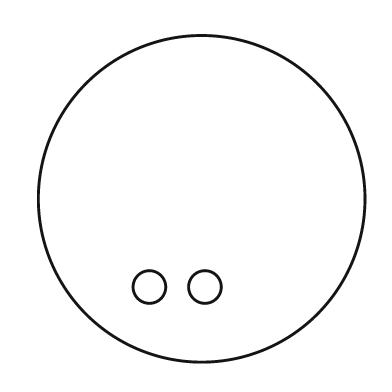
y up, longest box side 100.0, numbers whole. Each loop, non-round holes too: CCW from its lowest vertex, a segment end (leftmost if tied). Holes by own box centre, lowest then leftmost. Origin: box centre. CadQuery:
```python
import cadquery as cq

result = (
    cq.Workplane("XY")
    .moveTo(0.0, 0.0)
    .circle(50.0)
    .moveTo(-16.0, -27.0)
    .circle(5.0)
    .moveTo(1.0, -27.0)
    .circle(5.0)
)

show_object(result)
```